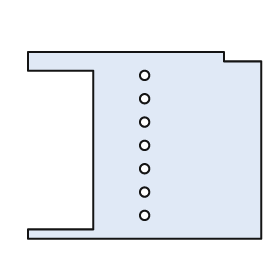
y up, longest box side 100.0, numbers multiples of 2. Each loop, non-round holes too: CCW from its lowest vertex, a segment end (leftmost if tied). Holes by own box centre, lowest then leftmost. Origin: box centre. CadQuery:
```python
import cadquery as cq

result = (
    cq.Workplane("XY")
    .moveTo(-50.0, -40.0)
    .lineTo(50.0, -40.0)
    .lineTo(50.0, 36.0)
    .lineTo(34.0, 36.0)
    .lineTo(34.0, 40.0)
    .lineTo(-50.0, 40.0)
    .lineTo(-50.0, 32.0)
    .lineTo(-22.0, 32.0)
    .lineTo(-22.0, -36.0)
    .lineTo(-50.0, -36.0)
    .close()
    .moveTo(0.0, -30.0)
    .circle(2.0)
    .moveTo(0.0, -20.0)
    .circle(2.0)
    .moveTo(0.0, -10.0)
    .circle(2.0)
    .moveTo(0.0, 0.0)
    .circle(2.0)
    .moveTo(0.0, 10.0)
    .circle(2.0)
    .moveTo(0.0, 20.0)
    .circle(2.0)
    .moveTo(0.0, 30.0)
    .circle(2.0)
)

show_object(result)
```